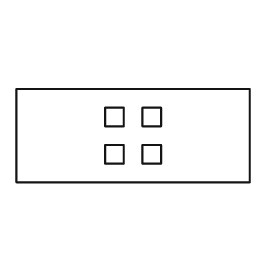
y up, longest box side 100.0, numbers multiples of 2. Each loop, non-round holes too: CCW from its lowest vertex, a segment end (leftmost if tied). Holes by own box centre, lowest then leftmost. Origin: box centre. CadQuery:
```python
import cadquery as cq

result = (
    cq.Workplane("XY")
    .moveTo(-50.0, -20.0)
    .lineTo(50.0, -20.0)
    .lineTo(50.0, 20.0)
    .lineTo(-50.0, 20.0)
    .close()
    .moveTo(-12.0, -12.0)
    .lineTo(-4.0, -12.0)
    .lineTo(-4.0, -4.0)
    .lineTo(-12.0, -4.0)
    .close()
    .moveTo(4.0, -12.0)
    .lineTo(12.0, -12.0)
    .lineTo(12.0, -4.0)
    .lineTo(4.0, -4.0)
    .close()
    .moveTo(-12.0, 4.0)
    .lineTo(-4.0, 4.0)
    .lineTo(-4.0, 12.0)
    .lineTo(-12.0, 12.0)
    .close()
    .moveTo(4.0, 4.0)
    .lineTo(12.0, 4.0)
    .lineTo(12.0, 12.0)
    .lineTo(4.0, 12.0)
    .close()
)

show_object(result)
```